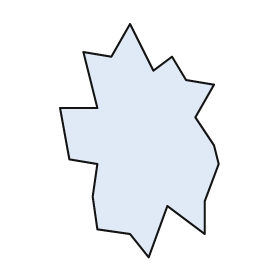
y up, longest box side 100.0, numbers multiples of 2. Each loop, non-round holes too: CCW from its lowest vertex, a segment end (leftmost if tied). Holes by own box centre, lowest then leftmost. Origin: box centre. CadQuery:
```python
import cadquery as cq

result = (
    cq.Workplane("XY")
    .moveTo(4.0, -50.0)
    .lineTo(12.0, -28.0)
    .lineTo(28.0, -40.0)
    .lineTo(28.0, -26.0)
    .lineTo(34.0, -10.0)
    .lineTo(32.0, -2.0)
    .lineTo(24.0, 10.0)
    .lineTo(32.0, 24.0)
    .lineTo(20.0, 26.0)
    .lineTo(14.0, 36.0)
    .lineTo(6.0, 30.0)
    .lineTo(-4.0, 50.0)
    .lineTo(-12.0, 36.0)
    .lineTo(-24.0, 38.0)
    .lineTo(-18.0, 14.0)
    .lineTo(-34.0, 14.0)
    .lineTo(-30.0, -8.0)
    .lineTo(-18.0, -10.0)
    .lineTo(-20.0, -24.0)
    .lineTo(-18.0, -38.0)
    .lineTo(-4.0, -40.0)
    .close()
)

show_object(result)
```